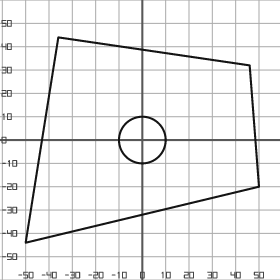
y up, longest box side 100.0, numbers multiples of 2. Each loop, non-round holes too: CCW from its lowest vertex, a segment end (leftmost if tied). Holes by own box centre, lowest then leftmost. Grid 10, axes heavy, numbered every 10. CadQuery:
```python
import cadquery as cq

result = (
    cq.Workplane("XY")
    .moveTo(-50.0, -44.0)
    .lineTo(50.0, -20.0)
    .lineTo(46.0, 32.0)
    .lineTo(-36.0, 44.0)
    .close()
    .moveTo(0.0, 0.0)
    .circle(10.0)
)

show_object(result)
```